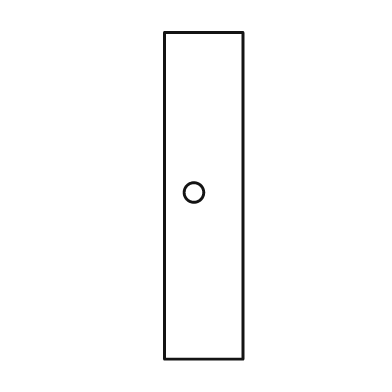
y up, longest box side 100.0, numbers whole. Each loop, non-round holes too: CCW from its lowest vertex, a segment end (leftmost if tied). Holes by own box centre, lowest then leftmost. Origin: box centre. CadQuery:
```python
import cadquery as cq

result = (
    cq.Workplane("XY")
    .moveTo(-12.0, -50.0)
    .lineTo(12.0, -50.0)
    .lineTo(12.0, 50.0)
    .lineTo(-12.0, 50.0)
    .close()
    .moveTo(-3.0, 1.0)
    .circle(3.0)
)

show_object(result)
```